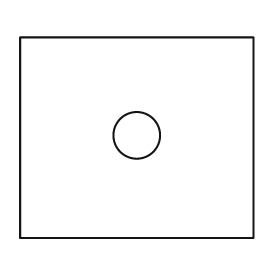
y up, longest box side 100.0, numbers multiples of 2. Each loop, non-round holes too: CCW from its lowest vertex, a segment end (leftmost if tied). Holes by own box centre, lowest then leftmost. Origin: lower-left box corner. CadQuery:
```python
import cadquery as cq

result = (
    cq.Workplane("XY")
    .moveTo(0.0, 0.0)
    .lineTo(100.0, 0.0)
    .lineTo(100.0, 86.0)
    .lineTo(0.0, 86.0)
    .close()
    .moveTo(50.0, 44.0)
    .circle(10.0)
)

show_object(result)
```